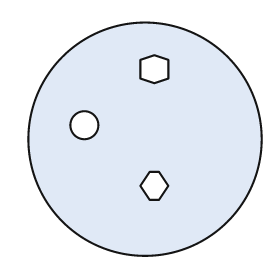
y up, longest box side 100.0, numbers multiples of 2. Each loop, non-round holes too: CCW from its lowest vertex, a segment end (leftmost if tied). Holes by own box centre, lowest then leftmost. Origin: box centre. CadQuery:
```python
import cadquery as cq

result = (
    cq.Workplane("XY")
    .moveTo(0.0, 0.0)
    .circle(50.0)
    .moveTo(2.0, -26.0)
    .lineTo(6.0, -26.0)
    .lineTo(10.0, -20.0)
    .lineTo(6.0, -14.0)
    .lineTo(2.0, -14.0)
    .lineTo(-2.0, -20.0)
    .close()
    .moveTo(-26.0, 6.0)
    .circle(6.0)
    .moveTo(4.0, 24.0)
    .lineTo(10.0, 26.0)
    .lineTo(10.0, 34.0)
    .lineTo(4.0, 36.0)
    .lineTo(-2.0, 34.0)
    .lineTo(-2.0, 26.0)
    .close()
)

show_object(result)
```